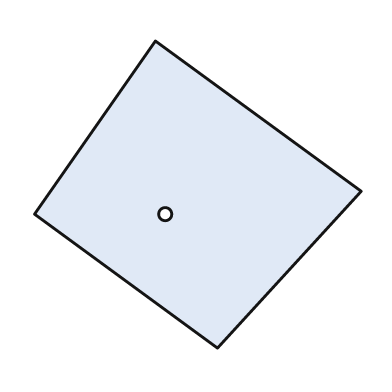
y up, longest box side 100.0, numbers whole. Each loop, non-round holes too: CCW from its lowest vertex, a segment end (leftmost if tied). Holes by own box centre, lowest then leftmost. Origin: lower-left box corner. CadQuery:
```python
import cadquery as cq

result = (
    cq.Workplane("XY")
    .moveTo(56.0, 0.0)
    .lineTo(100.0, 48.0)
    .lineTo(37.0, 94.0)
    .lineTo(0.0, 41.0)
    .close()
    .moveTo(40.0, 41.0)
    .circle(2.0)
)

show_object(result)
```